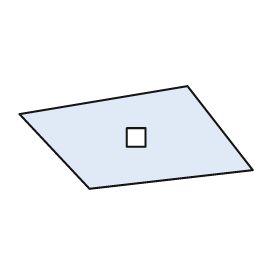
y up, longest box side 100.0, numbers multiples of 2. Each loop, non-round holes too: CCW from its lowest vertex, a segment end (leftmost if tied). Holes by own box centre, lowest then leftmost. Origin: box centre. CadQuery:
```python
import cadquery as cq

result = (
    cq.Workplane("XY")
    .moveTo(-20.0, -22.0)
    .lineTo(50.0, -14.0)
    .lineTo(22.0, 22.0)
    .lineTo(-50.0, 10.0)
    .close()
    .moveTo(-4.0, -4.0)
    .lineTo(4.0, -4.0)
    .lineTo(4.0, 4.0)
    .lineTo(-4.0, 4.0)
    .close()
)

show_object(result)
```